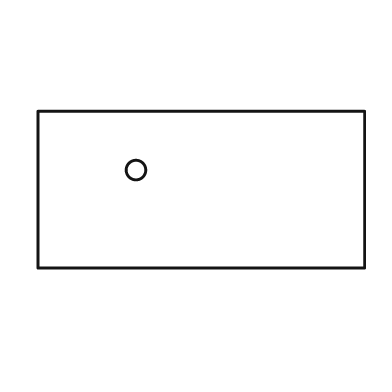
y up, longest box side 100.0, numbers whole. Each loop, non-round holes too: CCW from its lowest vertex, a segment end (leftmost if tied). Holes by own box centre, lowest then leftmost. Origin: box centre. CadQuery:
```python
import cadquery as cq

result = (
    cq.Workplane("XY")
    .moveTo(-50.0, -24.0)
    .lineTo(50.0, -24.0)
    .lineTo(50.0, 24.0)
    .lineTo(-50.0, 24.0)
    .close()
    .moveTo(-20.0, 6.0)
    .circle(3.0)
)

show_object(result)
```